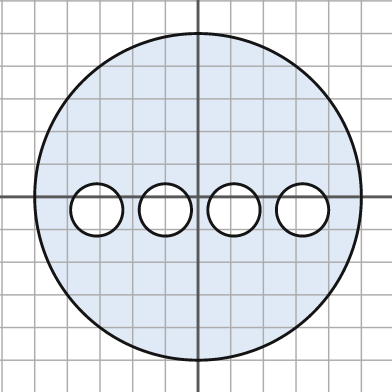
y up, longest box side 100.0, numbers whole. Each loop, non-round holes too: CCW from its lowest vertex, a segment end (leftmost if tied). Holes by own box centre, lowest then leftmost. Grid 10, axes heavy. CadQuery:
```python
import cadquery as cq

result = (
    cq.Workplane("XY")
    .moveTo(0.0, 0.0)
    .circle(50.0)
    .moveTo(-31.0, -4.0)
    .circle(8.0)
    .moveTo(-10.0, -4.0)
    .circle(8.0)
    .moveTo(11.0, -4.0)
    .circle(8.0)
    .moveTo(32.0, -4.0)
    .circle(8.0)
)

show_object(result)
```